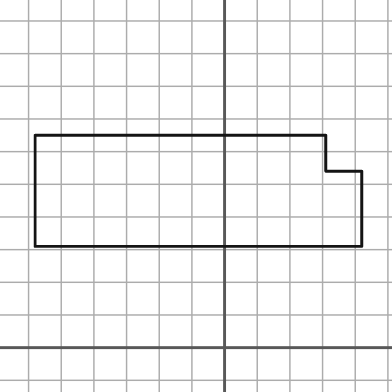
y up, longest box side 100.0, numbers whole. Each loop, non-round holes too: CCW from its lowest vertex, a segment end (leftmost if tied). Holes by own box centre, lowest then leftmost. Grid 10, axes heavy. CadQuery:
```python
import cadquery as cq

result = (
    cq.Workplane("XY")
    .moveTo(-58.0, 31.0)
    .lineTo(42.0, 31.0)
    .lineTo(42.0, 54.0)
    .lineTo(31.0, 54.0)
    .lineTo(31.0, 65.0)
    .lineTo(-58.0, 65.0)
    .close()
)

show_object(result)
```